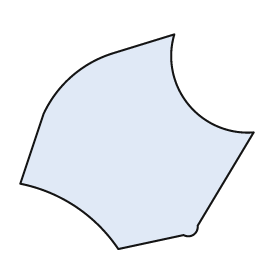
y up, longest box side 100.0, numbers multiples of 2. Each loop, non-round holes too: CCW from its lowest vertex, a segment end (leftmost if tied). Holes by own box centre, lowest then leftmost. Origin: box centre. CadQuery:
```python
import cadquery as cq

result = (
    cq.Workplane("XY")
    .moveTo(-8.0, -46.0)
    .lineTo(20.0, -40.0)
    .threePointArc((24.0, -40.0), (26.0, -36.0))
    .lineTo(50.0, 4.0)
    .threePointArc((22.0, 16.0), (16.0, 46.0))
    .lineTo(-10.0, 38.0)
    .threePointArc((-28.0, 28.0), (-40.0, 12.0))
    .lineTo(-50.0, -18.0)
    .threePointArc((-26.0, -28.0), (-8.0, -46.0))
    .close()
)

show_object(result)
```